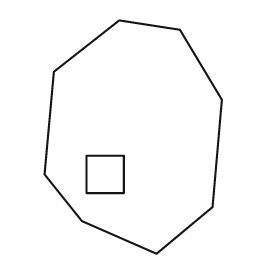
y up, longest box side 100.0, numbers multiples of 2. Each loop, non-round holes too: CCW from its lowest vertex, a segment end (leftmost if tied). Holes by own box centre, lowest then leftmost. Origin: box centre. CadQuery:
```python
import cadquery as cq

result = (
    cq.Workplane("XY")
    .moveTo(10.0, -50.0)
    .lineTo(34.0, -30.0)
    .lineTo(38.0, 16.0)
    .lineTo(20.0, 46.0)
    .lineTo(-6.0, 50.0)
    .lineTo(-34.0, 28.0)
    .lineTo(-38.0, -16.0)
    .lineTo(-22.0, -36.0)
    .close()
    .moveTo(-20.0, -24.0)
    .lineTo(-4.0, -24.0)
    .lineTo(-4.0, -8.0)
    .lineTo(-20.0, -8.0)
    .close()
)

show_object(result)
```